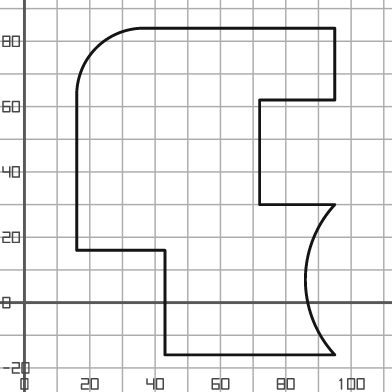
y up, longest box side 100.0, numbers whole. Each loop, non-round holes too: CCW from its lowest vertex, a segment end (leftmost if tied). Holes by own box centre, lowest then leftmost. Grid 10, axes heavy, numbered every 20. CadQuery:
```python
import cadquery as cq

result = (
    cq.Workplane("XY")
    .moveTo(43.0, -16.0)
    .lineTo(95.0, -16.0)
    .threePointArc((86.0, 7.0), (95.0, 30.0))
    .lineTo(72.0, 30.0)
    .lineTo(72.0, 62.0)
    .lineTo(95.0, 62.0)
    .lineTo(95.0, 84.0)
    .lineTo(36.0, 84.0)
    .threePointArc((22.0, 78.0), (16.0, 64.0))
    .lineTo(16.0, 16.0)
    .lineTo(43.0, 16.0)
    .close()
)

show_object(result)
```